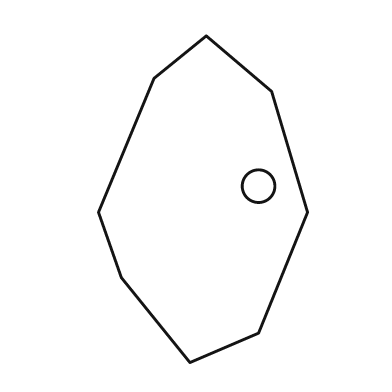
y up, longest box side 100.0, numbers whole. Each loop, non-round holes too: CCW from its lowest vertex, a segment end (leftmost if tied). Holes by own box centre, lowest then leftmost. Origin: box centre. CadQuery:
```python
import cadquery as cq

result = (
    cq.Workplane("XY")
    .moveTo(-4.0, -50.0)
    .lineTo(17.0, -41.0)
    .lineTo(32.0, -4.0)
    .lineTo(21.0, 33.0)
    .lineTo(1.0, 50.0)
    .lineTo(-15.0, 37.0)
    .lineTo(-32.0, -4.0)
    .lineTo(-25.0, -24.0)
    .close()
    .moveTo(17.0, 4.0)
    .circle(5.0)
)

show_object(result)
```